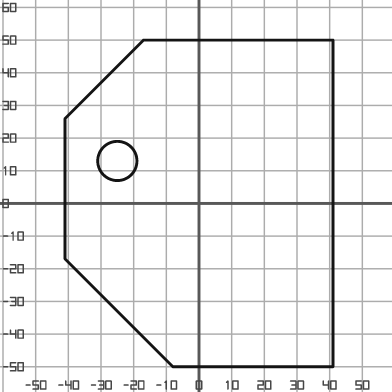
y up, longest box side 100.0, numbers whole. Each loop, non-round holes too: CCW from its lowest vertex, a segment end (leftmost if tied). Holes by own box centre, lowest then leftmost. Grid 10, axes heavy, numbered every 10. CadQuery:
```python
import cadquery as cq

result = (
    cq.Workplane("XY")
    .moveTo(-8.0, -50.0)
    .lineTo(41.0, -50.0)
    .lineTo(41.0, 50.0)
    .lineTo(-17.0, 50.0)
    .lineTo(-41.0, 26.0)
    .lineTo(-41.0, -17.0)
    .close()
    .moveTo(-25.0, 13.0)
    .circle(6.0)
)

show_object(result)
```